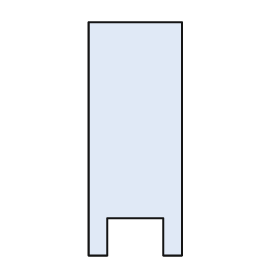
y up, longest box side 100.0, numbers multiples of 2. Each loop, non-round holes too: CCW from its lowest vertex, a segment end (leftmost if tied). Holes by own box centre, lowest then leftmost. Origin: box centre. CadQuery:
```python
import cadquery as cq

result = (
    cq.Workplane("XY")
    .moveTo(-20.0, -50.0)
    .lineTo(-12.0, -50.0)
    .lineTo(-12.0, -34.0)
    .lineTo(12.0, -34.0)
    .lineTo(12.0, -50.0)
    .lineTo(20.0, -50.0)
    .lineTo(20.0, 50.0)
    .lineTo(-20.0, 50.0)
    .close()
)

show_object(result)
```